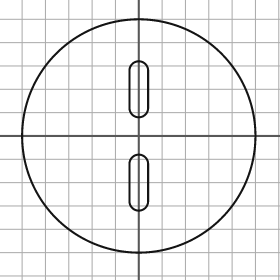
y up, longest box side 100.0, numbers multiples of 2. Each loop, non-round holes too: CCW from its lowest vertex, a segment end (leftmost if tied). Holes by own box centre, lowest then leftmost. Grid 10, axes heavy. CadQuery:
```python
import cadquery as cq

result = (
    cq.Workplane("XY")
    .moveTo(0.0, 0.0)
    .circle(50.0)
    .moveTo(-4.0, -28.0)
    .threePointArc((0.0, -32.0), (4.0, -28.0))
    .lineTo(4.0, -12.0)
    .threePointArc((0.0, -8.0), (-4.0, -12.0))
    .close()
    .moveTo(-4.0, 12.0)
    .threePointArc((0.0, 8.0), (4.0, 12.0))
    .lineTo(4.0, 28.0)
    .threePointArc((0.0, 32.0), (-4.0, 28.0))
    .close()
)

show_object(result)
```